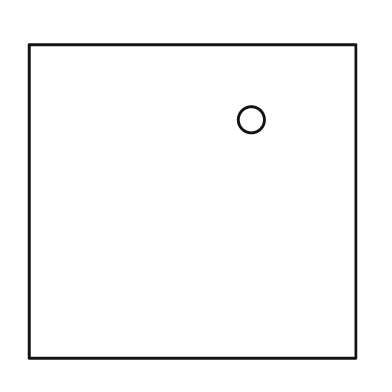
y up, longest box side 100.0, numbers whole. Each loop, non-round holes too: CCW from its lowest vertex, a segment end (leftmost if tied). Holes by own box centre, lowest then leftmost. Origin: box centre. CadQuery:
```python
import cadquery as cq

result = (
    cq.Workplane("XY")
    .moveTo(-50.0, -48.0)
    .lineTo(50.0, -48.0)
    .lineTo(50.0, 48.0)
    .lineTo(-50.0, 48.0)
    .close()
    .moveTo(18.0, 25.0)
    .circle(4.0)
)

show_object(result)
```